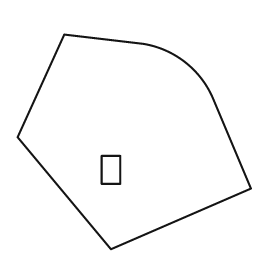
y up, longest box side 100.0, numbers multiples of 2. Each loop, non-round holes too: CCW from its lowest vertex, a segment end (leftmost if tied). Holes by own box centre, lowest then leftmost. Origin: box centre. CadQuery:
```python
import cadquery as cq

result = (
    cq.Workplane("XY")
    .moveTo(-10.0, -46.0)
    .lineTo(50.0, -20.0)
    .lineTo(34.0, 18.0)
    .threePointArc((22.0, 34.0), (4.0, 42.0))
    .lineTo(-30.0, 46.0)
    .lineTo(-50.0, 2.0)
    .close()
    .moveTo(-14.0, -18.0)
    .lineTo(-6.0, -18.0)
    .lineTo(-6.0, -6.0)
    .lineTo(-14.0, -6.0)
    .close()
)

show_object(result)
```